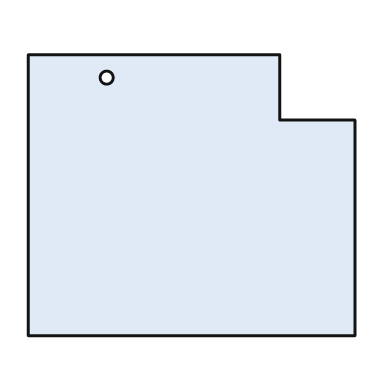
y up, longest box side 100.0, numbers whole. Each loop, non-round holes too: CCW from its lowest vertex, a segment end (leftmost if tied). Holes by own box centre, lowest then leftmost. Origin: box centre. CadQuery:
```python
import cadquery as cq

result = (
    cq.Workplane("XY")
    .moveTo(-50.0, -43.0)
    .lineTo(50.0, -43.0)
    .lineTo(50.0, 23.0)
    .lineTo(27.0, 23.0)
    .lineTo(27.0, 43.0)
    .lineTo(-50.0, 43.0)
    .close()
    .moveTo(-26.0, 36.0)
    .circle(2.0)
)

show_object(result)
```